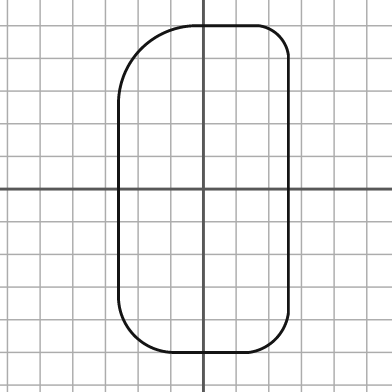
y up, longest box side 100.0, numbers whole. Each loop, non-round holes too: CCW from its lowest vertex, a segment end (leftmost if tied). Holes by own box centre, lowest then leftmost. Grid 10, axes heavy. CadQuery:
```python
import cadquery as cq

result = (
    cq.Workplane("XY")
    .moveTo(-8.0, -50.0)
    .lineTo(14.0, -50.0)
    .threePointArc((22.0, -46.0), (26.0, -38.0))
    .lineTo(26.0, 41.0)
    .threePointArc((23.0, 47.0), (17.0, 50.0))
    .lineTo(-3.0, 50.0)
    .threePointArc((-19.0, 43.0), (-26.0, 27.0))
    .lineTo(-26.0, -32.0)
    .threePointArc((-21.0, -45.0), (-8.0, -50.0))
    .close()
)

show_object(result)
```